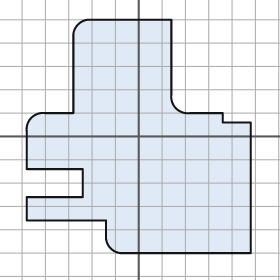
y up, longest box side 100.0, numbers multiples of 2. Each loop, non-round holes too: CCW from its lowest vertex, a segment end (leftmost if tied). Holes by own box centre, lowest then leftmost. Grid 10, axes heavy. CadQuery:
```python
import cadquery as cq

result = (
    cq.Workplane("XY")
    .moveTo(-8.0, -50.0)
    .lineTo(48.0, -50.0)
    .lineTo(48.0, 6.0)
    .lineTo(36.0, 6.0)
    .lineTo(36.0, 10.0)
    .lineTo(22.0, 10.0)
    .threePointArc((16.0, 12.0), (14.0, 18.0))
    .lineTo(14.0, 50.0)
    .lineTo(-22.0, 50.0)
    .threePointArc((-26.0, 48.0), (-28.0, 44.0))
    .lineTo(-28.0, 10.0)
    .lineTo(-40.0, 10.0)
    .threePointArc((-46.0, 8.0), (-48.0, 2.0))
    .lineTo(-48.0, -14.0)
    .lineTo(-24.0, -14.0)
    .lineTo(-24.0, -26.0)
    .lineTo(-48.0, -26.0)
    .lineTo(-48.0, -36.0)
    .lineTo(-14.0, -36.0)
    .lineTo(-14.0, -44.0)
    .threePointArc((-12.0, -48.0), (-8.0, -50.0))
    .close()
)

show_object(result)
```